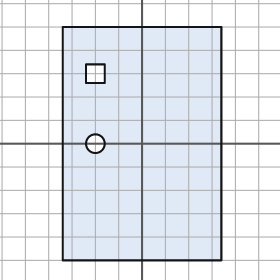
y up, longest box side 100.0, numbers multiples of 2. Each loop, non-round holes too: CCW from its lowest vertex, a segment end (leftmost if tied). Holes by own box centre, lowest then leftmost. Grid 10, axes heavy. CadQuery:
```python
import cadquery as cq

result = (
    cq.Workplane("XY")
    .moveTo(-34.0, -50.0)
    .lineTo(34.0, -50.0)
    .lineTo(34.0, 50.0)
    .lineTo(-34.0, 50.0)
    .close()
    .moveTo(-20.0, 0.0)
    .circle(4.0)
    .moveTo(-24.0, 26.0)
    .lineTo(-16.0, 26.0)
    .lineTo(-16.0, 34.0)
    .lineTo(-24.0, 34.0)
    .close()
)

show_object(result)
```